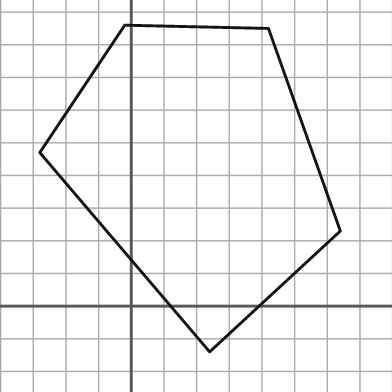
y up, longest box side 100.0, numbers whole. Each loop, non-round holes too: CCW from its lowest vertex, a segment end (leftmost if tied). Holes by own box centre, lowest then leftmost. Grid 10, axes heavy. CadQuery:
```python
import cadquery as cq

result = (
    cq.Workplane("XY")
    .moveTo(24.0, -14.0)
    .lineTo(64.0, 23.0)
    .lineTo(42.0, 85.0)
    .lineTo(-2.0, 86.0)
    .lineTo(-28.0, 47.0)
    .close()
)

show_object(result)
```